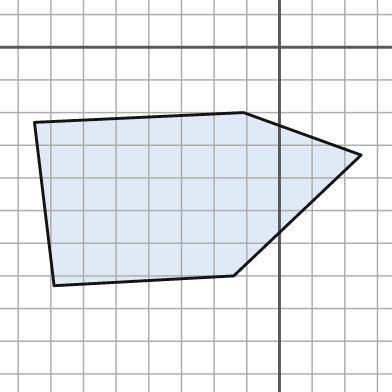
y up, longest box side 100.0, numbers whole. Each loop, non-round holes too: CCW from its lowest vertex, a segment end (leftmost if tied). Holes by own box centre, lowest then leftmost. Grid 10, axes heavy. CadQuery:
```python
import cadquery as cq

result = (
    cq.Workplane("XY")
    .moveTo(-69.0, -73.0)
    .lineTo(-14.0, -70.0)
    .lineTo(25.0, -33.0)
    .lineTo(-11.0, -20.0)
    .lineTo(-75.0, -23.0)
    .close()
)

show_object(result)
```